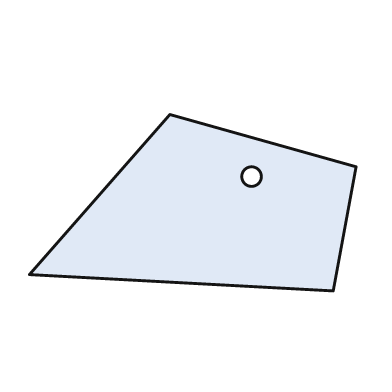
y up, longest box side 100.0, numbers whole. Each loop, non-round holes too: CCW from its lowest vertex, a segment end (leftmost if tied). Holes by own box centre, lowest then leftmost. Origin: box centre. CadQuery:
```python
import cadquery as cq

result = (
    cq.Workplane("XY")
    .moveTo(43.0, -27.0)
    .lineTo(50.0, 11.0)
    .lineTo(-7.0, 27.0)
    .lineTo(-50.0, -22.0)
    .close()
    .moveTo(18.0, 8.0)
    .circle(3.0)
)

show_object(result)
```